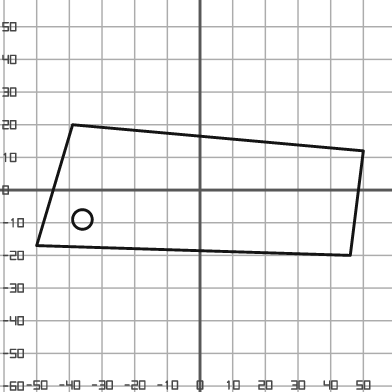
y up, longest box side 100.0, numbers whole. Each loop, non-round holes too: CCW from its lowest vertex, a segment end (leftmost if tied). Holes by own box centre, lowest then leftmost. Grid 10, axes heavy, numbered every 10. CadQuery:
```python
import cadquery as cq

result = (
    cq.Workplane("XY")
    .moveTo(46.0, -20.0)
    .lineTo(50.0, 12.0)
    .lineTo(-39.0, 20.0)
    .lineTo(-50.0, -17.0)
    .close()
    .moveTo(-36.0, -9.0)
    .circle(3.0)
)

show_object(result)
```